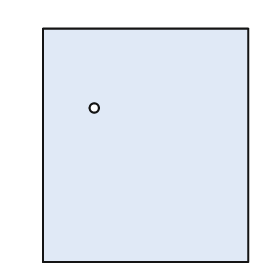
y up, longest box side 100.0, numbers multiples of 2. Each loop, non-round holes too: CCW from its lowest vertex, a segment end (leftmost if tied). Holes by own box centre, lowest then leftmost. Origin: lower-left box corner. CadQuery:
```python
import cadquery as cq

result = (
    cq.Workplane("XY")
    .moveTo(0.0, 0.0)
    .lineTo(88.0, 0.0)
    .lineTo(88.0, 100.0)
    .lineTo(0.0, 100.0)
    .close()
    .moveTo(22.0, 66.0)
    .circle(2.0)
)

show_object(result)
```